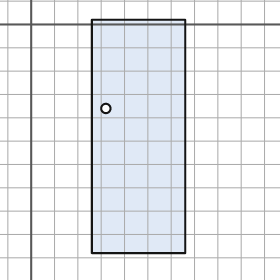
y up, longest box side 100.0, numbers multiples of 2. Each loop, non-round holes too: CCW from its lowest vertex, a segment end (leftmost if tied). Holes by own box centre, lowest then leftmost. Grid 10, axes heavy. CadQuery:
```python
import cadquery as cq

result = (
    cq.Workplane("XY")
    .moveTo(26.0, -98.0)
    .lineTo(66.0, -98.0)
    .lineTo(66.0, 2.0)
    .lineTo(26.0, 2.0)
    .close()
    .moveTo(32.0, -36.0)
    .circle(2.0)
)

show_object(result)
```